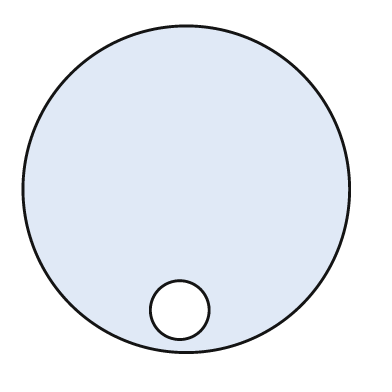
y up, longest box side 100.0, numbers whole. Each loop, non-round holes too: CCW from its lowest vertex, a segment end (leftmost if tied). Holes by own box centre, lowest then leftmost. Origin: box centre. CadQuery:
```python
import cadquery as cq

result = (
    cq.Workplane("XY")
    .moveTo(0.0, 0.0)
    .circle(50.0)
    .moveTo(-2.0, -37.0)
    .circle(9.0)
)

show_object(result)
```